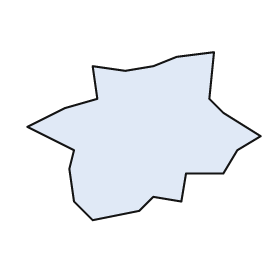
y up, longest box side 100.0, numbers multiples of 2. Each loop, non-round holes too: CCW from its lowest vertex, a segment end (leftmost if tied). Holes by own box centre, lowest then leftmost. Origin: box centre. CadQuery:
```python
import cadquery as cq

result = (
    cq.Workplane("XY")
    .moveTo(-22.0, -36.0)
    .lineTo(-2.0, -32.0)
    .lineTo(4.0, -26.0)
    .lineTo(16.0, -28.0)
    .lineTo(18.0, -16.0)
    .lineTo(34.0, -16.0)
    .lineTo(40.0, -6.0)
    .lineTo(50.0, 0.0)
    .lineTo(34.0, 10.0)
    .lineTo(28.0, 16.0)
    .lineTo(30.0, 36.0)
    .lineTo(14.0, 34.0)
    .lineTo(4.0, 30.0)
    .lineTo(-8.0, 28.0)
    .lineTo(-22.0, 30.0)
    .lineTo(-20.0, 16.0)
    .lineTo(-34.0, 12.0)
    .lineTo(-50.0, 4.0)
    .lineTo(-30.0, -6.0)
    .lineTo(-32.0, -14.0)
    .lineTo(-30.0, -28.0)
    .close()
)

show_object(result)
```